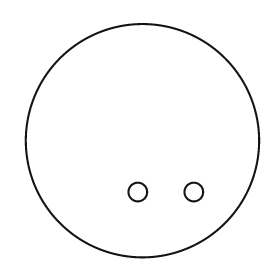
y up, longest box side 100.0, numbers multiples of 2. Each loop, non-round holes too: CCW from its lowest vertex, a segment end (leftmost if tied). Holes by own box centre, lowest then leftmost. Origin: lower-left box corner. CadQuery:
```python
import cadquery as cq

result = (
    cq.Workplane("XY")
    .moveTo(50.0, 50.0)
    .circle(50.0)
    .moveTo(48.0, 28.0)
    .circle(4.0)
    .moveTo(72.0, 28.0)
    .circle(4.0)
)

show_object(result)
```